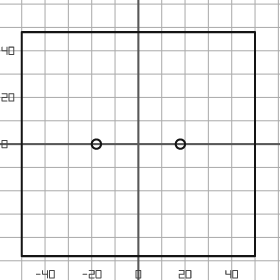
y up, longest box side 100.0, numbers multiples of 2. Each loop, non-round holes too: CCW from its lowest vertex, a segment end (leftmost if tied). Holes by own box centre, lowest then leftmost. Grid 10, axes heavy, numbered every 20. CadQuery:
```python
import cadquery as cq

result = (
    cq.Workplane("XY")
    .moveTo(-50.0, -48.0)
    .lineTo(50.0, -48.0)
    .lineTo(50.0, 48.0)
    .lineTo(-50.0, 48.0)
    .close()
    .moveTo(-18.0, 0.0)
    .circle(2.0)
    .moveTo(18.0, 0.0)
    .circle(2.0)
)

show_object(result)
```